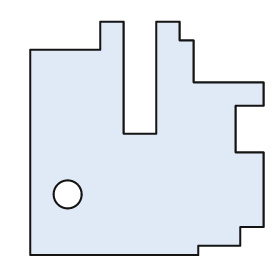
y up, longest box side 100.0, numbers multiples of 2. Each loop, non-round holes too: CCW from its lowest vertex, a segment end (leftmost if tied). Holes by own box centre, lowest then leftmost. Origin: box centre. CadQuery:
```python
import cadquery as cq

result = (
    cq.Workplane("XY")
    .moveTo(-50.0, -50.0)
    .lineTo(22.0, -50.0)
    .lineTo(22.0, -46.0)
    .lineTo(40.0, -46.0)
    .lineTo(40.0, -38.0)
    .lineTo(50.0, -38.0)
    .lineTo(50.0, -6.0)
    .lineTo(38.0, -6.0)
    .lineTo(38.0, 14.0)
    .lineTo(50.0, 14.0)
    .lineTo(50.0, 24.0)
    .lineTo(20.0, 24.0)
    .lineTo(20.0, 42.0)
    .lineTo(14.0, 42.0)
    .lineTo(14.0, 50.0)
    .lineTo(4.0, 50.0)
    .lineTo(4.0, 2.0)
    .lineTo(-10.0, 2.0)
    .lineTo(-10.0, 50.0)
    .lineTo(-20.0, 50.0)
    .lineTo(-20.0, 38.0)
    .lineTo(-50.0, 38.0)
    .close()
    .moveTo(-34.0, -24.0)
    .circle(6.0)
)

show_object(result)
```